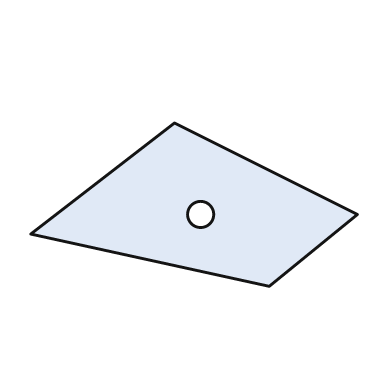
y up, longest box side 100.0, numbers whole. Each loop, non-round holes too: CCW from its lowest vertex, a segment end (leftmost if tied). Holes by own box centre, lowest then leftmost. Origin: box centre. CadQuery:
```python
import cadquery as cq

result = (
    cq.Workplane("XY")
    .moveTo(23.0, -25.0)
    .lineTo(50.0, -3.0)
    .lineTo(-6.0, 25.0)
    .lineTo(-50.0, -9.0)
    .close()
    .moveTo(2.0, -3.0)
    .circle(4.0)
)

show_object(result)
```